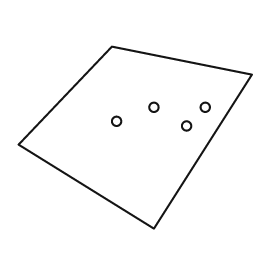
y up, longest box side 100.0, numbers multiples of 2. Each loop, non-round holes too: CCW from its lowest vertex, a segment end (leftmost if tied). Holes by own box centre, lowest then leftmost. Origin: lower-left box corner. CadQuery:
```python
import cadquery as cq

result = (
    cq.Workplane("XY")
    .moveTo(58.0, 0.0)
    .lineTo(100.0, 66.0)
    .lineTo(40.0, 78.0)
    .lineTo(0.0, 36.0)
    .close()
    .moveTo(72.0, 44.0)
    .circle(2.0)
    .moveTo(42.0, 46.0)
    .circle(2.0)
    .moveTo(58.0, 52.0)
    .circle(2.0)
    .moveTo(80.0, 52.0)
    .circle(2.0)
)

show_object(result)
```